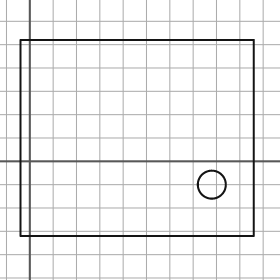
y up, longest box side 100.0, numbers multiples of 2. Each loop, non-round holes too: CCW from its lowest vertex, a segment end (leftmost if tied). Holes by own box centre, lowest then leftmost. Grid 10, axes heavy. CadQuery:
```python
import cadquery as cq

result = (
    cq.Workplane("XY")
    .moveTo(-4.0, -32.0)
    .lineTo(96.0, -32.0)
    .lineTo(96.0, 52.0)
    .lineTo(-4.0, 52.0)
    .close()
    .moveTo(78.0, -10.0)
    .circle(6.0)
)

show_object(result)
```